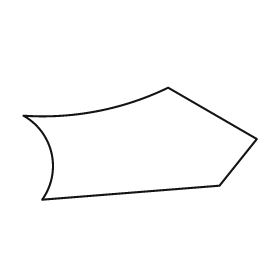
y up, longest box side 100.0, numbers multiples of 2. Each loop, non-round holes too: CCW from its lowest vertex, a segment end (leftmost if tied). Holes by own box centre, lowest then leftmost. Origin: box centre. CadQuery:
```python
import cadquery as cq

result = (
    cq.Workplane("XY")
    .moveTo(-42.0, -24.0)
    .lineTo(34.0, -18.0)
    .lineTo(50.0, 2.0)
    .lineTo(12.0, 24.0)
    .threePointArc((-18.0, 14.0), (-50.0, 12.0))
    .threePointArc((-38.0, -4.0), (-42.0, -24.0))
    .close()
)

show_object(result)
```